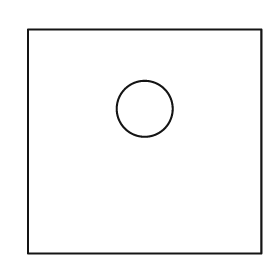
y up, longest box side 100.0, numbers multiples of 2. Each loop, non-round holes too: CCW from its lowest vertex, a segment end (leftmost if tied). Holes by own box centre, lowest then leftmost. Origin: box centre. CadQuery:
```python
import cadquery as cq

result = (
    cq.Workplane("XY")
    .moveTo(-50.0, -48.0)
    .lineTo(50.0, -48.0)
    .lineTo(50.0, 48.0)
    .lineTo(-50.0, 48.0)
    .close()
    .moveTo(0.0, 14.0)
    .circle(12.0)
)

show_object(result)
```